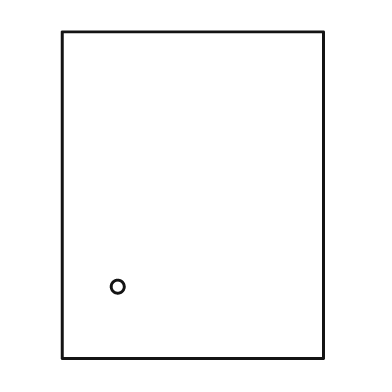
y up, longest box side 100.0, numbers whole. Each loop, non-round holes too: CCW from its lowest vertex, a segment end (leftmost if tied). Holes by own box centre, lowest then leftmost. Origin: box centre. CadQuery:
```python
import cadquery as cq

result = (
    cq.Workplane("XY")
    .moveTo(-40.0, -50.0)
    .lineTo(40.0, -50.0)
    .lineTo(40.0, 50.0)
    .lineTo(-40.0, 50.0)
    .close()
    .moveTo(-23.0, -28.0)
    .circle(2.0)
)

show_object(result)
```